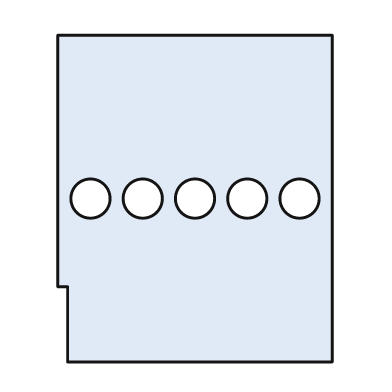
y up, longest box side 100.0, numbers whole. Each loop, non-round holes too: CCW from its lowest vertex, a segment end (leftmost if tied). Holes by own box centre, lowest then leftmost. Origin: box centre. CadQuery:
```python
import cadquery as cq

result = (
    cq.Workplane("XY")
    .moveTo(-39.0, -50.0)
    .lineTo(42.0, -50.0)
    .lineTo(42.0, 50.0)
    .lineTo(-42.0, 50.0)
    .lineTo(-42.0, -27.0)
    .lineTo(-39.0, -27.0)
    .close()
    .moveTo(-32.0, 0.0)
    .circle(6.0)
    .moveTo(-16.0, 0.0)
    .circle(6.0)
    .moveTo(0.0, 0.0)
    .circle(6.0)
    .moveTo(16.0, 0.0)
    .circle(6.0)
    .moveTo(32.0, 0.0)
    .circle(6.0)
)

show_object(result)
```